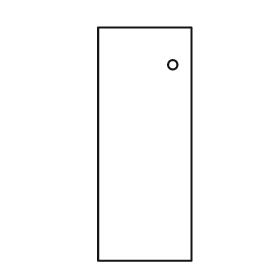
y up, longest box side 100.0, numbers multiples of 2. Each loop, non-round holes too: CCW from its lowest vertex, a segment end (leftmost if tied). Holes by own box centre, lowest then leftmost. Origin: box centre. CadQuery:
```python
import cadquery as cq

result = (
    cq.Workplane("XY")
    .moveTo(-20.0, -50.0)
    .lineTo(20.0, -50.0)
    .lineTo(20.0, 50.0)
    .lineTo(-20.0, 50.0)
    .close()
    .moveTo(12.0, 34.0)
    .circle(2.0)
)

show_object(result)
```